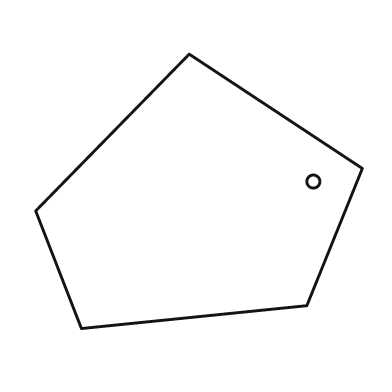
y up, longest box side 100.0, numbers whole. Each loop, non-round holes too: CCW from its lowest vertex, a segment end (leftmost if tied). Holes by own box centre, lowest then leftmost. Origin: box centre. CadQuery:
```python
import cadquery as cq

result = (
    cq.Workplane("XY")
    .moveTo(-36.0, -42.0)
    .lineTo(33.0, -35.0)
    .lineTo(50.0, 7.0)
    .lineTo(-3.0, 42.0)
    .lineTo(-50.0, -6.0)
    .close()
    .moveTo(35.0, 3.0)
    .circle(2.0)
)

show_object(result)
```